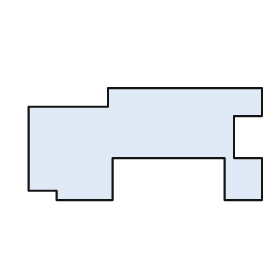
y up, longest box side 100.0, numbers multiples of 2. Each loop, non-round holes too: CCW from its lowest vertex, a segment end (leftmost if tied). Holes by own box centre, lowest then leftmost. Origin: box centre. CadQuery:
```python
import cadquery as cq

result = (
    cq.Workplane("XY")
    .moveTo(-38.0, -24.0)
    .lineTo(-14.0, -24.0)
    .lineTo(-14.0, -6.0)
    .lineTo(34.0, -6.0)
    .lineTo(34.0, -24.0)
    .lineTo(50.0, -24.0)
    .lineTo(50.0, -6.0)
    .lineTo(38.0, -6.0)
    .lineTo(38.0, 12.0)
    .lineTo(50.0, 12.0)
    .lineTo(50.0, 24.0)
    .lineTo(-16.0, 24.0)
    .lineTo(-16.0, 16.0)
    .lineTo(-50.0, 16.0)
    .lineTo(-50.0, -20.0)
    .lineTo(-38.0, -20.0)
    .close()
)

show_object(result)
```